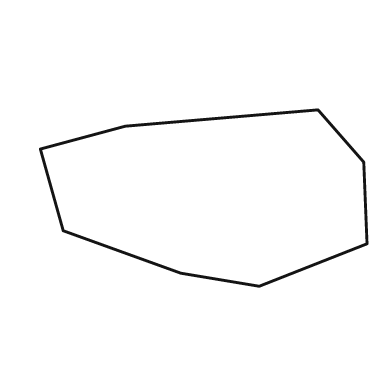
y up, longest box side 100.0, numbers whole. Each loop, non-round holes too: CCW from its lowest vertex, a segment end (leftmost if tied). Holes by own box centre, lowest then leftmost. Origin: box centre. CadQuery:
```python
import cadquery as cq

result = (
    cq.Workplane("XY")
    .moveTo(17.0, -27.0)
    .lineTo(50.0, -14.0)
    .lineTo(49.0, 11.0)
    .lineTo(35.0, 27.0)
    .lineTo(-24.0, 22.0)
    .lineTo(-50.0, 15.0)
    .lineTo(-43.0, -10.0)
    .lineTo(-7.0, -23.0)
    .close()
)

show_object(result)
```